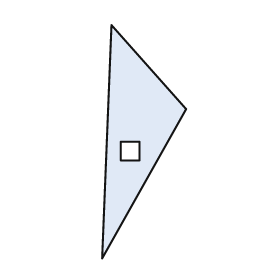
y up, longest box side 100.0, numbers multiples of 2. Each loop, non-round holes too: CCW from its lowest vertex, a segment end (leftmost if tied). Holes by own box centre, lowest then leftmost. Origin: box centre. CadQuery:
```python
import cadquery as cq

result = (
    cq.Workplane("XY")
    .moveTo(-18.0, -50.0)
    .lineTo(18.0, 14.0)
    .lineTo(-14.0, 50.0)
    .close()
    .moveTo(-10.0, -8.0)
    .lineTo(-2.0, -8.0)
    .lineTo(-2.0, 0.0)
    .lineTo(-10.0, 0.0)
    .close()
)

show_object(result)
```